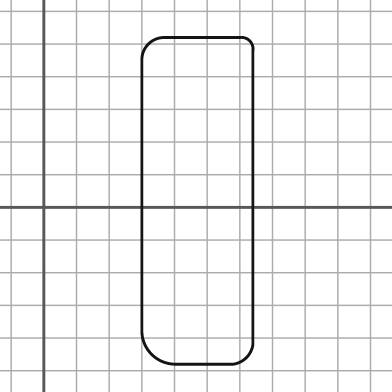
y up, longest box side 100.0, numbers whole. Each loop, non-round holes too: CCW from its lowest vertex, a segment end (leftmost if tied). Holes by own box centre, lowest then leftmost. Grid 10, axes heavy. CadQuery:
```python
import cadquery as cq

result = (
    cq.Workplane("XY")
    .moveTo(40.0, -48.0)
    .lineTo(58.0, -48.0)
    .threePointArc((62.0, -46.0), (64.0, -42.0))
    .lineTo(64.0, 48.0)
    .threePointArc((63.0, 51.0), (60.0, 52.0))
    .lineTo(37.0, 52.0)
    .threePointArc((32.0, 50.0), (30.0, 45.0))
    .lineTo(30.0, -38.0)
    .threePointArc((33.0, -45.0), (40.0, -48.0))
    .close()
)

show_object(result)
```